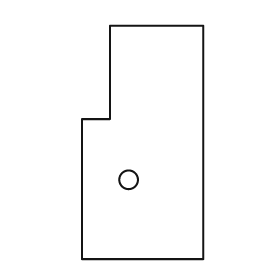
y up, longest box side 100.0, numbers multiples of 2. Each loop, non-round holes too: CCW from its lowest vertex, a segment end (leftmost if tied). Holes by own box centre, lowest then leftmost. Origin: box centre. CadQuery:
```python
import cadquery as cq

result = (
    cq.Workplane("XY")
    .moveTo(-26.0, -50.0)
    .lineTo(26.0, -50.0)
    .lineTo(26.0, 50.0)
    .lineTo(-14.0, 50.0)
    .lineTo(-14.0, 10.0)
    .lineTo(-26.0, 10.0)
    .close()
    .moveTo(-6.0, -16.0)
    .circle(4.0)
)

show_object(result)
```